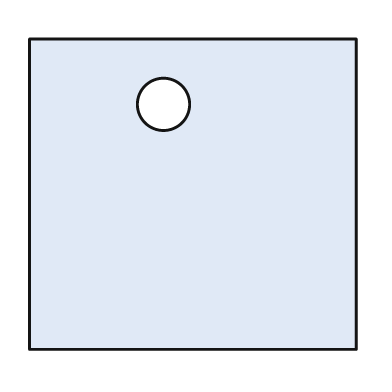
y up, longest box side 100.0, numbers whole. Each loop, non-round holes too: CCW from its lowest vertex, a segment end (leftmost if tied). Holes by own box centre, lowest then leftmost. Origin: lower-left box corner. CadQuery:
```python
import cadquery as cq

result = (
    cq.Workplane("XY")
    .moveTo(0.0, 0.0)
    .lineTo(100.0, 0.0)
    .lineTo(100.0, 95.0)
    .lineTo(0.0, 95.0)
    .close()
    .moveTo(41.0, 75.0)
    .circle(8.0)
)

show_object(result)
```